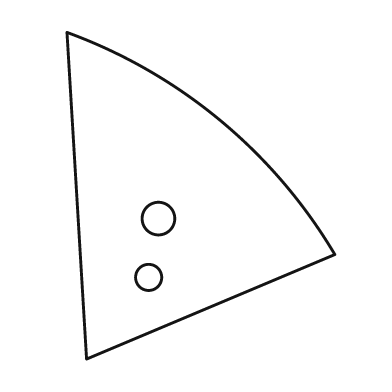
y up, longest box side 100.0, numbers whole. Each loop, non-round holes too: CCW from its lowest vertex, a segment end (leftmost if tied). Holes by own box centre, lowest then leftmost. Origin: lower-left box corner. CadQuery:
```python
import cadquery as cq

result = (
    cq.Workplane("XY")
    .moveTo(6.0, 0.0)
    .lineTo(82.0, 32.0)
    .threePointArc((47.0, 73.0), (0.0, 100.0))
    .close()
    .moveTo(25.0, 25.0)
    .circle(4.0)
    .moveTo(28.0, 43.0)
    .circle(5.0)
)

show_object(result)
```